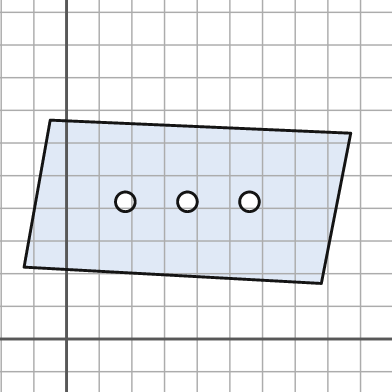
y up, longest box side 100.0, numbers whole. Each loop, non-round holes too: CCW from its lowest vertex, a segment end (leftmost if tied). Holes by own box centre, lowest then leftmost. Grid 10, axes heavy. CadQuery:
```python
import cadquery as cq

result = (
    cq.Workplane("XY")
    .moveTo(78.0, 17.0)
    .lineTo(87.0, 63.0)
    .lineTo(-5.0, 67.0)
    .lineTo(-13.0, 22.0)
    .close()
    .moveTo(18.0, 42.0)
    .circle(3.0)
    .moveTo(37.0, 42.0)
    .circle(3.0)
    .moveTo(56.0, 42.0)
    .circle(3.0)
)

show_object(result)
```